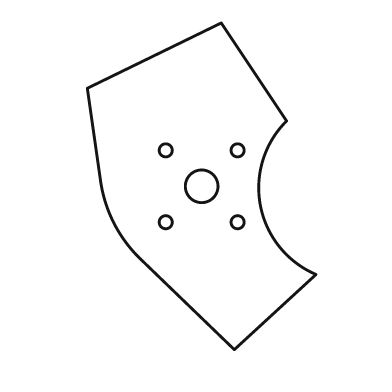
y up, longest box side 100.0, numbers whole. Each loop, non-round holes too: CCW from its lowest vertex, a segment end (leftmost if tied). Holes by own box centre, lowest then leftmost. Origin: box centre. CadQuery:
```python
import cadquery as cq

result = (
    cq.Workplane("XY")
    .moveTo(10.0, -50.0)
    .lineTo(35.0, -27.0)
    .threePointArc((18.0, -6.0), (26.0, 20.0))
    .lineTo(6.0, 50.0)
    .lineTo(-35.0, 30.0)
    .lineTo(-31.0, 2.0)
    .threePointArc((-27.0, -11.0), (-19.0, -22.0))
    .close()
    .moveTo(-11.0, -11.0)
    .circle(2.0)
    .moveTo(11.0, -11.0)
    .circle(2.0)
    .moveTo(0.0, 0.0)
    .circle(5.0)
    .moveTo(-11.0, 11.0)
    .circle(2.0)
    .moveTo(11.0, 11.0)
    .circle(2.0)
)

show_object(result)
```